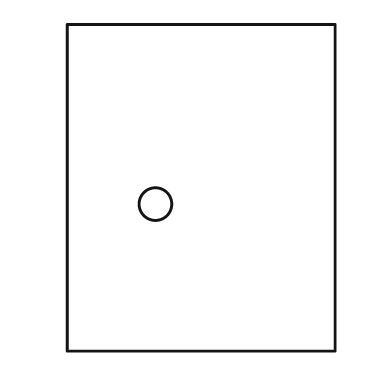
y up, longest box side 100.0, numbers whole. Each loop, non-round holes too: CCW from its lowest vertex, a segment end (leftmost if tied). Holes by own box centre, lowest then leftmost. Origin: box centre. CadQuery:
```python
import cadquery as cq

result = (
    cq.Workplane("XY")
    .moveTo(-41.0, -50.0)
    .lineTo(41.0, -50.0)
    .lineTo(41.0, 50.0)
    .lineTo(-41.0, 50.0)
    .close()
    .moveTo(-14.0, -5.0)
    .circle(5.0)
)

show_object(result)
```